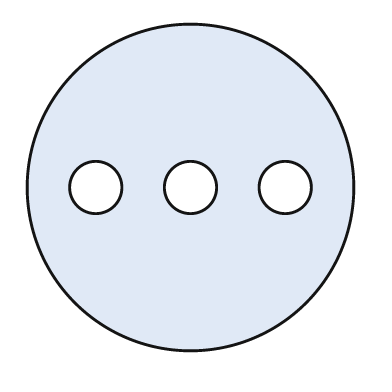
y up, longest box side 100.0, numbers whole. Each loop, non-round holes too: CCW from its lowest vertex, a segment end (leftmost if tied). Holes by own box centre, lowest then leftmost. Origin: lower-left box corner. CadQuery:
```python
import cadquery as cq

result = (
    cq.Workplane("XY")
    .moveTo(50.0, 50.0)
    .circle(50.0)
    .moveTo(21.0, 50.0)
    .circle(8.0)
    .moveTo(50.0, 50.0)
    .circle(8.0)
    .moveTo(79.0, 50.0)
    .circle(8.0)
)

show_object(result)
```